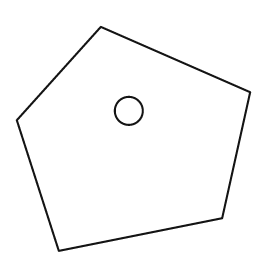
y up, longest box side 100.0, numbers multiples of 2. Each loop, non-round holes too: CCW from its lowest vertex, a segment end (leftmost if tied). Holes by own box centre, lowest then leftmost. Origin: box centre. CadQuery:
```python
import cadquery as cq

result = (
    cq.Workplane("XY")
    .moveTo(-32.0, -48.0)
    .lineTo(38.0, -34.0)
    .lineTo(50.0, 20.0)
    .lineTo(-14.0, 48.0)
    .lineTo(-50.0, 8.0)
    .close()
    .moveTo(-2.0, 12.0)
    .circle(6.0)
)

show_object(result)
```